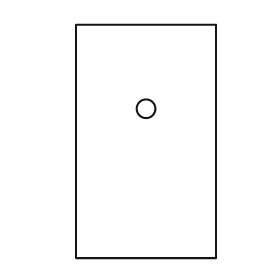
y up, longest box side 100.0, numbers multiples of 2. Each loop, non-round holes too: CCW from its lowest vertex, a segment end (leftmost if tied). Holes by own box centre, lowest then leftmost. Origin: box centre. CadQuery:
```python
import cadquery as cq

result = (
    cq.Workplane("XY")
    .moveTo(-30.0, -50.0)
    .lineTo(30.0, -50.0)
    .lineTo(30.0, 50.0)
    .lineTo(-30.0, 50.0)
    .close()
    .moveTo(0.0, 14.0)
    .circle(4.0)
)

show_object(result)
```